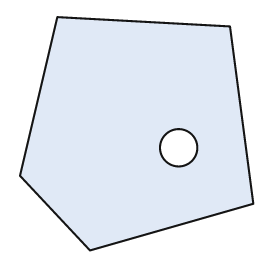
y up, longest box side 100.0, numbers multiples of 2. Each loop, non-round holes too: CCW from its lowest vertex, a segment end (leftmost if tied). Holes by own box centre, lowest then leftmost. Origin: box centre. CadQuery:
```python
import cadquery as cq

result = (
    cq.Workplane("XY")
    .moveTo(-20.0, -50.0)
    .lineTo(50.0, -30.0)
    .lineTo(40.0, 46.0)
    .lineTo(-34.0, 50.0)
    .lineTo(-50.0, -18.0)
    .close()
    .moveTo(18.0, -6.0)
    .circle(8.0)
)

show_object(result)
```